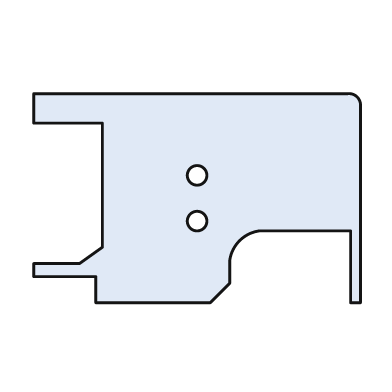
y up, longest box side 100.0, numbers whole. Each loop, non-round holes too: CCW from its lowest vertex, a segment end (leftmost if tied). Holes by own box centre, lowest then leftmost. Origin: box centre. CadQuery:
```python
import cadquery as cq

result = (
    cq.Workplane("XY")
    .moveTo(-31.0, -32.0)
    .lineTo(4.0, -32.0)
    .lineTo(10.0, -26.0)
    .lineTo(10.0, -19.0)
    .threePointArc((13.0, -13.0), (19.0, -10.0))
    .lineTo(47.0, -10.0)
    .lineTo(47.0, -32.0)
    .lineTo(50.0, -32.0)
    .lineTo(50.0, 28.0)
    .threePointArc((49.0, 31.0), (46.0, 32.0))
    .lineTo(-50.0, 32.0)
    .lineTo(-50.0, 23.0)
    .lineTo(-29.0, 23.0)
    .lineTo(-29.0, -15.0)
    .lineTo(-36.0, -20.0)
    .lineTo(-50.0, -20.0)
    .lineTo(-50.0, -24.0)
    .lineTo(-31.0, -24.0)
    .close()
    .moveTo(0.0, -7.0)
    .circle(3.0)
    .moveTo(0.0, 7.0)
    .circle(3.0)
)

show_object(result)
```